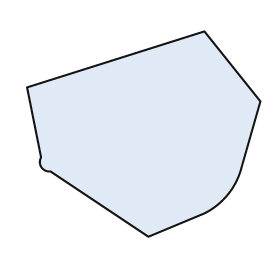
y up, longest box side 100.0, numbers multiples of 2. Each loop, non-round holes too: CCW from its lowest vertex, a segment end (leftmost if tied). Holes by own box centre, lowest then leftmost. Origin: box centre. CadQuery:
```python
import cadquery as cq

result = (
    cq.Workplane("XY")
    .moveTo(2.0, -44.0)
    .lineTo(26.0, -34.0)
    .threePointArc((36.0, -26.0), (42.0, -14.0))
    .lineTo(50.0, 14.0)
    .lineTo(26.0, 44.0)
    .lineTo(-50.0, 20.0)
    .lineTo(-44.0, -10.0)
    .threePointArc((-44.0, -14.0), (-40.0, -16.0))
    .close()
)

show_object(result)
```